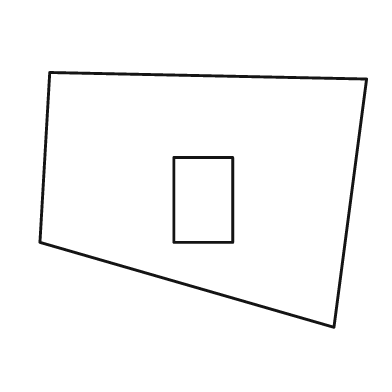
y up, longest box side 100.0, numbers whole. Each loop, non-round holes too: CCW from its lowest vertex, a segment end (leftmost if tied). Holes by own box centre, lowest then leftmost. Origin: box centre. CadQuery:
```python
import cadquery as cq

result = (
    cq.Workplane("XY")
    .moveTo(40.0, -39.0)
    .lineTo(50.0, 37.0)
    .lineTo(-47.0, 39.0)
    .lineTo(-50.0, -13.0)
    .close()
    .moveTo(-9.0, -13.0)
    .lineTo(9.0, -13.0)
    .lineTo(9.0, 13.0)
    .lineTo(-9.0, 13.0)
    .close()
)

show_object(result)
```